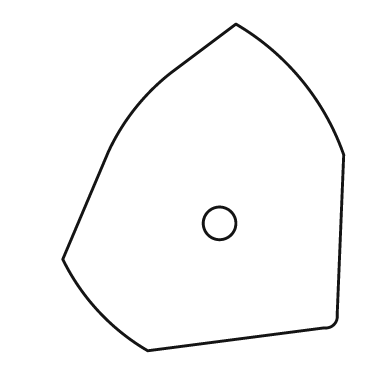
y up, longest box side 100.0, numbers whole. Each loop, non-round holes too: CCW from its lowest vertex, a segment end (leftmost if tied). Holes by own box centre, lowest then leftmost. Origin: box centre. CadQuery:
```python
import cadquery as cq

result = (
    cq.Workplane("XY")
    .moveTo(-17.0, -50.0)
    .lineTo(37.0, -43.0)
    .threePointArc((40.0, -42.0), (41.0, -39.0))
    .lineTo(43.0, 10.0)
    .threePointArc((30.0, 33.0), (10.0, 50.0))
    .lineTo(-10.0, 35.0)
    .threePointArc((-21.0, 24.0), (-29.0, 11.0))
    .lineTo(-43.0, -22.0)
    .threePointArc((-32.0, -38.0), (-17.0, -50.0))
    .close()
    .moveTo(5.0, -11.0)
    .circle(5.0)
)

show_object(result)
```